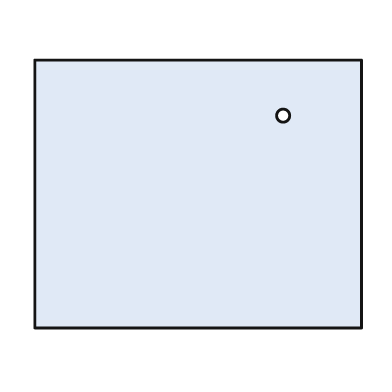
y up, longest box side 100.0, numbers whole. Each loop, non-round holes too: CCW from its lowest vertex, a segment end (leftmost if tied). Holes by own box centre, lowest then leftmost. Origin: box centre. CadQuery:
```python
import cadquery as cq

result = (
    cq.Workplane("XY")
    .moveTo(-50.0, -41.0)
    .lineTo(50.0, -41.0)
    .lineTo(50.0, 41.0)
    .lineTo(-50.0, 41.0)
    .close()
    .moveTo(26.0, 24.0)
    .circle(2.0)
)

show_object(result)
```